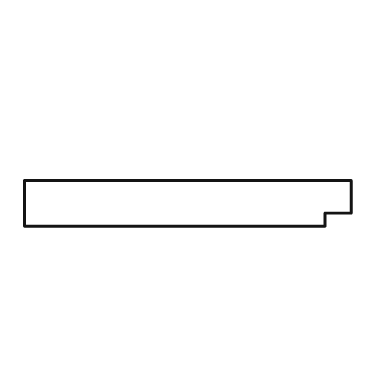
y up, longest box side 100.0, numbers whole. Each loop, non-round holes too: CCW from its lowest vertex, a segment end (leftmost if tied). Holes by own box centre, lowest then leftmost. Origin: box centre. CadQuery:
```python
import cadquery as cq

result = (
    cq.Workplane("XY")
    .moveTo(-50.0, -7.0)
    .lineTo(42.0, -7.0)
    .lineTo(42.0, -3.0)
    .lineTo(50.0, -3.0)
    .lineTo(50.0, 7.0)
    .lineTo(-50.0, 7.0)
    .close()
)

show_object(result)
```